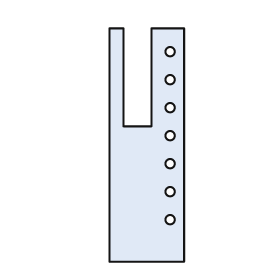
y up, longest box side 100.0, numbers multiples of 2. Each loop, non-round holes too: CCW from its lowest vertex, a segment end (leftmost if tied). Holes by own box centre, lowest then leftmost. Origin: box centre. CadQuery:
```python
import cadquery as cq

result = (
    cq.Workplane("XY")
    .moveTo(-16.0, -50.0)
    .lineTo(16.0, -50.0)
    .lineTo(16.0, 50.0)
    .lineTo(2.0, 50.0)
    .lineTo(2.0, 8.0)
    .lineTo(-10.0, 8.0)
    .lineTo(-10.0, 50.0)
    .lineTo(-16.0, 50.0)
    .close()
    .moveTo(10.0, -32.0)
    .circle(2.0)
    .moveTo(10.0, -20.0)
    .circle(2.0)
    .moveTo(10.0, -8.0)
    .circle(2.0)
    .moveTo(10.0, 4.0)
    .circle(2.0)
    .moveTo(10.0, 16.0)
    .circle(2.0)
    .moveTo(10.0, 28.0)
    .circle(2.0)
    .moveTo(10.0, 40.0)
    .circle(2.0)
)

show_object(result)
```